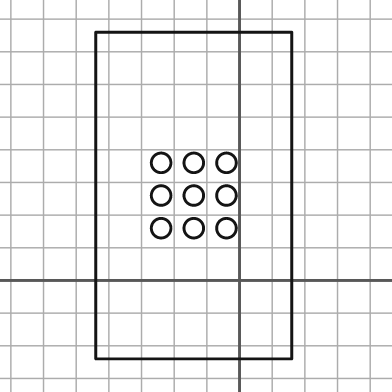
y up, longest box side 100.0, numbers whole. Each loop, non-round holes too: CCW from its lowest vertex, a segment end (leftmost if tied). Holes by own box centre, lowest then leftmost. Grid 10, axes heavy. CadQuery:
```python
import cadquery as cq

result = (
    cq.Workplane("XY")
    .moveTo(-44.0, -24.0)
    .lineTo(16.0, -24.0)
    .lineTo(16.0, 76.0)
    .lineTo(-44.0, 76.0)
    .close()
    .moveTo(-24.0, 16.0)
    .circle(3.0)
    .moveTo(-14.0, 16.0)
    .circle(3.0)
    .moveTo(-4.0, 16.0)
    .circle(3.0)
    .moveTo(-24.0, 26.0)
    .circle(3.0)
    .moveTo(-14.0, 26.0)
    .circle(3.0)
    .moveTo(-4.0, 26.0)
    .circle(3.0)
    .moveTo(-24.0, 36.0)
    .circle(3.0)
    .moveTo(-14.0, 36.0)
    .circle(3.0)
    .moveTo(-4.0, 36.0)
    .circle(3.0)
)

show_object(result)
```